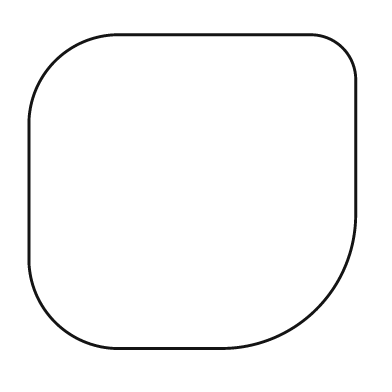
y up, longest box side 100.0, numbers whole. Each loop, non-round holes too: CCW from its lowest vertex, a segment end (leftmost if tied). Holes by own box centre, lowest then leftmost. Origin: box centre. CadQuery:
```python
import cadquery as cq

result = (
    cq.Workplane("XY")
    .moveTo(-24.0, -48.0)
    .lineTo(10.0, -48.0)
    .threePointArc((38.0, -36.0), (50.0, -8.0))
    .lineTo(50.0, 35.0)
    .threePointArc((46.0, 44.0), (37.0, 48.0))
    .lineTo(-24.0, 48.0)
    .threePointArc((-42.0, 40.0), (-50.0, 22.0))
    .lineTo(-50.0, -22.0)
    .threePointArc((-42.0, -40.0), (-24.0, -48.0))
    .close()
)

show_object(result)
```